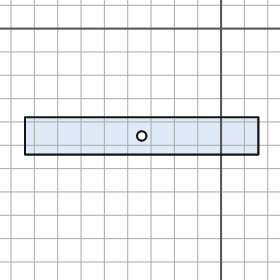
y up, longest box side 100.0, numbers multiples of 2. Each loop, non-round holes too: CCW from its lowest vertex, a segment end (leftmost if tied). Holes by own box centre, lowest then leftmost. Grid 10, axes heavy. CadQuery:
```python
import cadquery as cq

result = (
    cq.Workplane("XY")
    .moveTo(-84.0, -54.0)
    .lineTo(16.0, -54.0)
    .lineTo(16.0, -38.0)
    .lineTo(-84.0, -38.0)
    .close()
    .moveTo(-34.0, -46.0)
    .circle(2.0)
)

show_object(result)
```